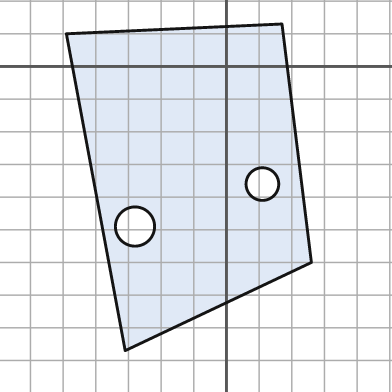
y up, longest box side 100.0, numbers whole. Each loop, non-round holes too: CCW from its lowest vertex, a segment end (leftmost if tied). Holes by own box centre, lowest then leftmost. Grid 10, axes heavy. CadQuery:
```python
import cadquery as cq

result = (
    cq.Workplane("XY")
    .moveTo(-31.0, -87.0)
    .lineTo(26.0, -60.0)
    .lineTo(17.0, 13.0)
    .lineTo(-49.0, 10.0)
    .close()
    .moveTo(-28.0, -49.0)
    .circle(6.0)
    .moveTo(11.0, -36.0)
    .circle(5.0)
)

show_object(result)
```